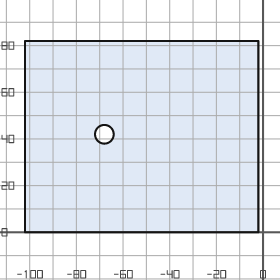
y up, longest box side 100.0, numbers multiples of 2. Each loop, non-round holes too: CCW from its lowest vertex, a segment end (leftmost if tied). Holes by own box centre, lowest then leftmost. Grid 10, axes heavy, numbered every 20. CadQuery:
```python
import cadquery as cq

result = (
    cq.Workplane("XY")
    .moveTo(-102.0, 0.0)
    .lineTo(-2.0, 0.0)
    .lineTo(-2.0, 82.0)
    .lineTo(-102.0, 82.0)
    .close()
    .moveTo(-68.0, 42.0)
    .circle(4.0)
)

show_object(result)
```